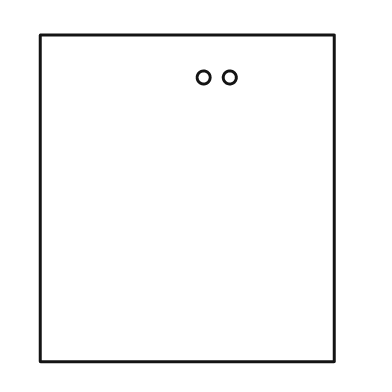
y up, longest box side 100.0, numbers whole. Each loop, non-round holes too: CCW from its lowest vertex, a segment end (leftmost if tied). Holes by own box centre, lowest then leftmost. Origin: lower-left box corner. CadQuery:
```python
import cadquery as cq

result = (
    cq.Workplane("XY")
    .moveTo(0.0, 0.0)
    .lineTo(90.0, 0.0)
    .lineTo(90.0, 100.0)
    .lineTo(0.0, 100.0)
    .close()
    .moveTo(50.0, 87.0)
    .circle(2.0)
    .moveTo(58.0, 87.0)
    .circle(2.0)
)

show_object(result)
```